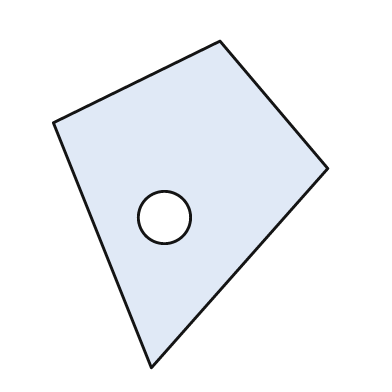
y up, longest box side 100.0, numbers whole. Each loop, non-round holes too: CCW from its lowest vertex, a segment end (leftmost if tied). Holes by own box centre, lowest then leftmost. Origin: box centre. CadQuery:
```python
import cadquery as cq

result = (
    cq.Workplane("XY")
    .moveTo(-12.0, -50.0)
    .lineTo(42.0, 11.0)
    .lineTo(9.0, 50.0)
    .lineTo(-42.0, 25.0)
    .close()
    .moveTo(-8.0, -4.0)
    .circle(8.0)
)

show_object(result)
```